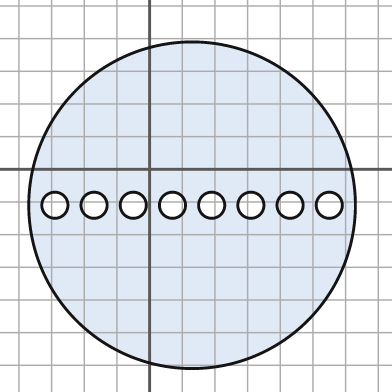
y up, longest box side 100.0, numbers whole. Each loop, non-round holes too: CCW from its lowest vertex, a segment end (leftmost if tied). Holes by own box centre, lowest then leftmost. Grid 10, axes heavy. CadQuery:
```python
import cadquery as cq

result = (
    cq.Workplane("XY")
    .moveTo(13.0, -11.0)
    .circle(50.0)
    .moveTo(-29.0, -11.0)
    .circle(4.0)
    .moveTo(-17.0, -11.0)
    .circle(4.0)
    .moveTo(-5.0, -11.0)
    .circle(4.0)
    .moveTo(7.0, -11.0)
    .circle(4.0)
    .moveTo(19.0, -11.0)
    .circle(4.0)
    .moveTo(31.0, -11.0)
    .circle(4.0)
    .moveTo(43.0, -11.0)
    .circle(4.0)
    .moveTo(55.0, -11.0)
    .circle(4.0)
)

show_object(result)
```